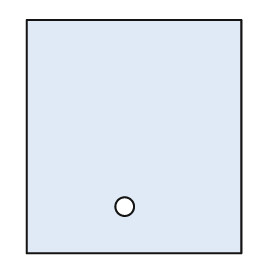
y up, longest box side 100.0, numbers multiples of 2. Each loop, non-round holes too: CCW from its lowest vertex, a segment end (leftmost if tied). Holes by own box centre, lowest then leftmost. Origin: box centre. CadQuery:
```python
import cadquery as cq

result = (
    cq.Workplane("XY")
    .moveTo(-46.0, -50.0)
    .lineTo(46.0, -50.0)
    .lineTo(46.0, 50.0)
    .lineTo(-46.0, 50.0)
    .close()
    .moveTo(-4.0, -30.0)
    .circle(4.0)
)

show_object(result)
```